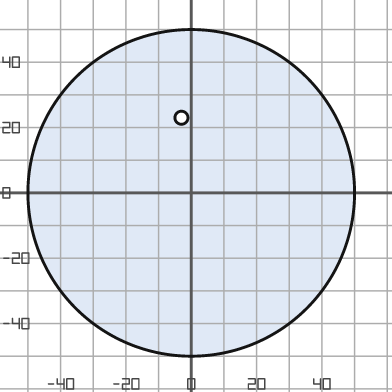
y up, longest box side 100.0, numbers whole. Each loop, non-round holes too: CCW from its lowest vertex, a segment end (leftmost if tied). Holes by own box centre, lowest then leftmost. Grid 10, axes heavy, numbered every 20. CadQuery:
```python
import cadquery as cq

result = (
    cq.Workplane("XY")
    .moveTo(0.0, 0.0)
    .circle(50.0)
    .moveTo(-3.0, 23.0)
    .circle(2.0)
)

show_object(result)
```